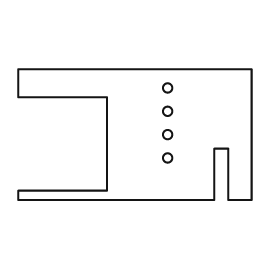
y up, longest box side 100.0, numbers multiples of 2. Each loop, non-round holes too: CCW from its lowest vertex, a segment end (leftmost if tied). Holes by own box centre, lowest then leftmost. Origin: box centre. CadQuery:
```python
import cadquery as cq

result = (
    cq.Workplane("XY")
    .moveTo(-50.0, -28.0)
    .lineTo(34.0, -28.0)
    .lineTo(34.0, -6.0)
    .lineTo(40.0, -6.0)
    .lineTo(40.0, -28.0)
    .lineTo(50.0, -28.0)
    .lineTo(50.0, 28.0)
    .lineTo(-50.0, 28.0)
    .lineTo(-50.0, 16.0)
    .lineTo(-12.0, 16.0)
    .lineTo(-12.0, -24.0)
    .lineTo(-50.0, -24.0)
    .close()
    .moveTo(14.0, -10.0)
    .circle(2.0)
    .moveTo(14.0, 0.0)
    .circle(2.0)
    .moveTo(14.0, 10.0)
    .circle(2.0)
    .moveTo(14.0, 20.0)
    .circle(2.0)
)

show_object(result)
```